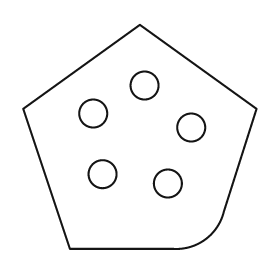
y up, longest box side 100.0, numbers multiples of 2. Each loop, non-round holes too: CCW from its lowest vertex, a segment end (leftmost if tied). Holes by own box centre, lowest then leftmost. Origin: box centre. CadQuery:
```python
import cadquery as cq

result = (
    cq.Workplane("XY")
    .moveTo(-30.0, -48.0)
    .lineTo(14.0, -48.0)
    .threePointArc((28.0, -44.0), (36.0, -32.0))
    .lineTo(50.0, 12.0)
    .lineTo(0.0, 48.0)
    .lineTo(-50.0, 12.0)
    .close()
    .moveTo(12.0, -20.0)
    .circle(6.0)
    .moveTo(-16.0, -16.0)
    .circle(6.0)
    .moveTo(22.0, 4.0)
    .circle(6.0)
    .moveTo(-20.0, 10.0)
    .circle(6.0)
    .moveTo(2.0, 22.0)
    .circle(6.0)
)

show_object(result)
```